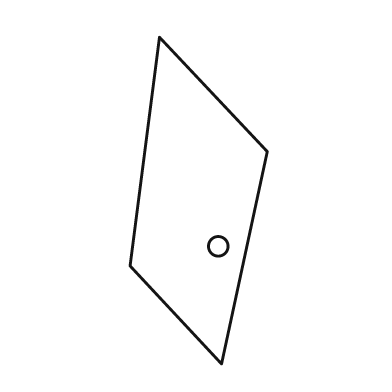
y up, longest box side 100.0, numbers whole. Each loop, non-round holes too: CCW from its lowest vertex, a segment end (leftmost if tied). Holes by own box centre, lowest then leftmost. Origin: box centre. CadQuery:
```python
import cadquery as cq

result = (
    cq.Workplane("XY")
    .moveTo(7.0, -50.0)
    .lineTo(21.0, 15.0)
    .lineTo(-12.0, 50.0)
    .lineTo(-21.0, -20.0)
    .close()
    .moveTo(6.0, -14.0)
    .circle(3.0)
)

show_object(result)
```